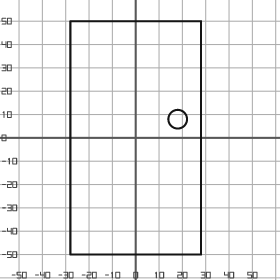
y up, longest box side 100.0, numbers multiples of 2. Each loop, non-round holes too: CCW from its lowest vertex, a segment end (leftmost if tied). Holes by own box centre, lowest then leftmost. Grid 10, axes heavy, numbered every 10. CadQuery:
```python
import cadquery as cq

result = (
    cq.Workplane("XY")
    .moveTo(-28.0, -50.0)
    .lineTo(28.0, -50.0)
    .lineTo(28.0, 50.0)
    .lineTo(-28.0, 50.0)
    .close()
    .moveTo(18.0, 8.0)
    .circle(4.0)
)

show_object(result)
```